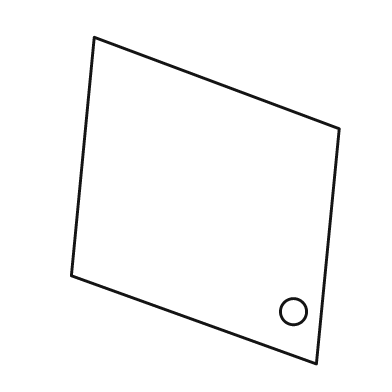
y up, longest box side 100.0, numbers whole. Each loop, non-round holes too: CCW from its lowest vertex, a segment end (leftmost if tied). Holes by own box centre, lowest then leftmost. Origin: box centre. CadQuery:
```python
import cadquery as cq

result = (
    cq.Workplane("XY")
    .moveTo(34.0, -50.0)
    .lineTo(41.0, 22.0)
    .lineTo(-34.0, 50.0)
    .lineTo(-41.0, -23.0)
    .close()
    .moveTo(27.0, -34.0)
    .circle(4.0)
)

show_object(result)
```